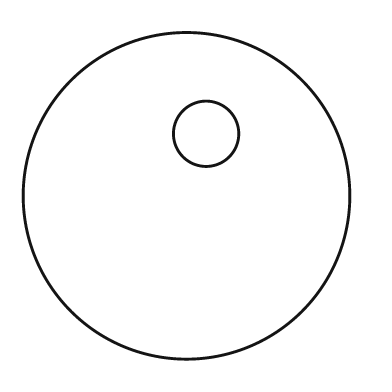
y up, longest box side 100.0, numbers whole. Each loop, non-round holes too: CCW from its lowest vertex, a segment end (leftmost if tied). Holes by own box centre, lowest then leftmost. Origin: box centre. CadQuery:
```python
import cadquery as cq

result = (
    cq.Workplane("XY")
    .moveTo(0.0, 0.0)
    .circle(50.0)
    .moveTo(6.0, 19.0)
    .circle(10.0)
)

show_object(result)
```